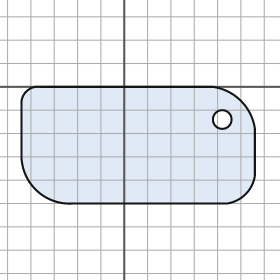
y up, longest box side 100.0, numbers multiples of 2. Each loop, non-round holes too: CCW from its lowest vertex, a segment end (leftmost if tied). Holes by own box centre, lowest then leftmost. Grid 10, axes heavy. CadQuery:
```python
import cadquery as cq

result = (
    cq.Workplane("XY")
    .moveTo(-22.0, -50.0)
    .lineTo(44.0, -50.0)
    .threePointArc((52.0, -46.0), (56.0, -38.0))
    .lineTo(56.0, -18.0)
    .threePointArc((50.0, -6.0), (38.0, 0.0))
    .lineTo(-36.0, 0.0)
    .threePointArc((-42.0, -2.0), (-44.0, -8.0))
    .lineTo(-44.0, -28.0)
    .threePointArc((-38.0, -44.0), (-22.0, -50.0))
    .close()
    .moveTo(42.0, -14.0)
    .circle(4.0)
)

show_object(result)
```